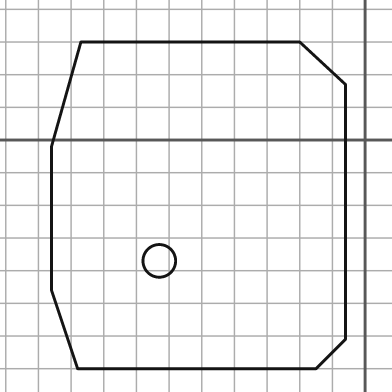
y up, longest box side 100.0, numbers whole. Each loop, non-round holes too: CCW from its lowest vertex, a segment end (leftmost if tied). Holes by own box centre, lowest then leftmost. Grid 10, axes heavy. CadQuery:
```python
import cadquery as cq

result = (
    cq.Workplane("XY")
    .moveTo(-88.0, -70.0)
    .lineTo(-15.0, -70.0)
    .lineTo(-6.0, -61.0)
    .lineTo(-6.0, 17.0)
    .lineTo(-20.0, 30.0)
    .lineTo(-87.0, 30.0)
    .lineTo(-96.0, -2.0)
    .lineTo(-96.0, -46.0)
    .close()
    .moveTo(-63.0, -37.0)
    .circle(5.0)
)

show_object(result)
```